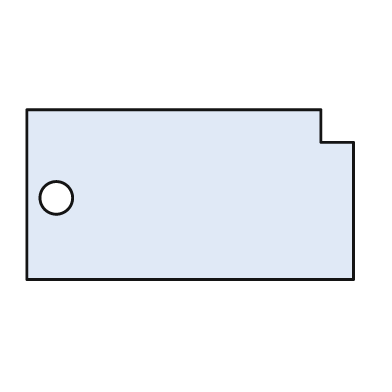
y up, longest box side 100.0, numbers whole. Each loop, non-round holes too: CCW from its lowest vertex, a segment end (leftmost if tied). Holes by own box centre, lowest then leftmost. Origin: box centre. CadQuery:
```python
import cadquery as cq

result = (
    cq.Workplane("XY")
    .moveTo(-50.0, -26.0)
    .lineTo(50.0, -26.0)
    .lineTo(50.0, 16.0)
    .lineTo(40.0, 16.0)
    .lineTo(40.0, 26.0)
    .lineTo(-50.0, 26.0)
    .close()
    .moveTo(-41.0, -1.0)
    .circle(5.0)
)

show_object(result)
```